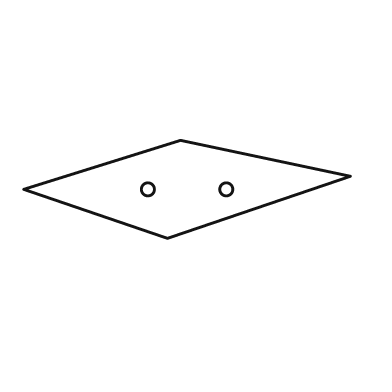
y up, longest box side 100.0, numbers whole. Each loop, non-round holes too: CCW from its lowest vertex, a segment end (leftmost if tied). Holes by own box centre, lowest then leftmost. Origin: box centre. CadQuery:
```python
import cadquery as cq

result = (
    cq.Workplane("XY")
    .moveTo(-6.0, -15.0)
    .lineTo(50.0, 4.0)
    .lineTo(-2.0, 15.0)
    .lineTo(-50.0, 0.0)
    .close()
    .moveTo(-12.0, 0.0)
    .circle(2.0)
    .moveTo(12.0, 0.0)
    .circle(2.0)
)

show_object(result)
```